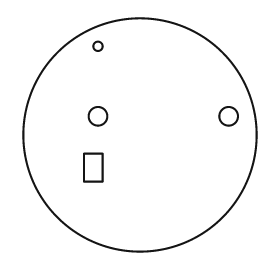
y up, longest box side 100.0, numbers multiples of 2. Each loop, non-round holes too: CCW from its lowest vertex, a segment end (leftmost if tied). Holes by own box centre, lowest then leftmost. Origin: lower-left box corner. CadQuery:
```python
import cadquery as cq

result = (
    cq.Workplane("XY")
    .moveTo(50.0, 50.0)
    .circle(50.0)
    .moveTo(26.0, 30.0)
    .lineTo(34.0, 30.0)
    .lineTo(34.0, 42.0)
    .lineTo(26.0, 42.0)
    .close()
    .moveTo(32.0, 58.0)
    .circle(4.0)
    .moveTo(88.0, 58.0)
    .circle(4.0)
    .moveTo(32.0, 88.0)
    .circle(2.0)
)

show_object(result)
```